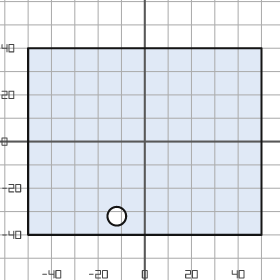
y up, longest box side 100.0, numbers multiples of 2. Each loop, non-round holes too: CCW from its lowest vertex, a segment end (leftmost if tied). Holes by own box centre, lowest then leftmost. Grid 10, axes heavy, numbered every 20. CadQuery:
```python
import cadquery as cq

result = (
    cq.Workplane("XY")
    .moveTo(-50.0, -40.0)
    .lineTo(50.0, -40.0)
    .lineTo(50.0, 40.0)
    .lineTo(-50.0, 40.0)
    .close()
    .moveTo(-12.0, -32.0)
    .circle(4.0)
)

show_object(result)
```